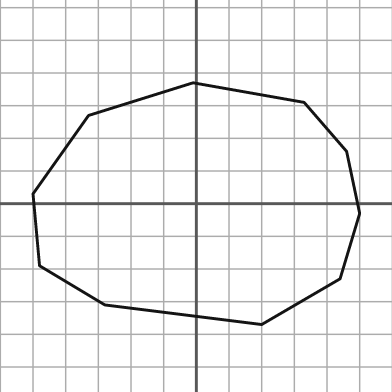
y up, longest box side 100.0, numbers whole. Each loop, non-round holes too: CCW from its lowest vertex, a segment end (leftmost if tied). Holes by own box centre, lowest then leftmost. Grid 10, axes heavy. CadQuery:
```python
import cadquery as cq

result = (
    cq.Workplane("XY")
    .moveTo(20.0, -37.0)
    .lineTo(44.0, -23.0)
    .lineTo(50.0, -3.0)
    .lineTo(46.0, 16.0)
    .lineTo(33.0, 31.0)
    .lineTo(-1.0, 37.0)
    .lineTo(-33.0, 27.0)
    .lineTo(-50.0, 3.0)
    .lineTo(-48.0, -19.0)
    .lineTo(-28.0, -31.0)
    .close()
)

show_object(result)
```